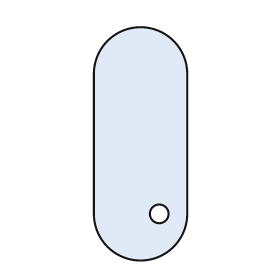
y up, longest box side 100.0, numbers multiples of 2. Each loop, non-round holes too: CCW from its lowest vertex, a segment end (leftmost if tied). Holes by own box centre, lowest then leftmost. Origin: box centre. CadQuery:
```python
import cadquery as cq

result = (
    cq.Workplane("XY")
    .moveTo(-20.0, -30.0)
    .threePointArc((0.0, -50.0), (20.0, -30.0))
    .lineTo(20.0, 30.0)
    .threePointArc((0.0, 50.0), (-20.0, 30.0))
    .close()
    .moveTo(8.0, -30.0)
    .circle(4.0)
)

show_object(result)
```